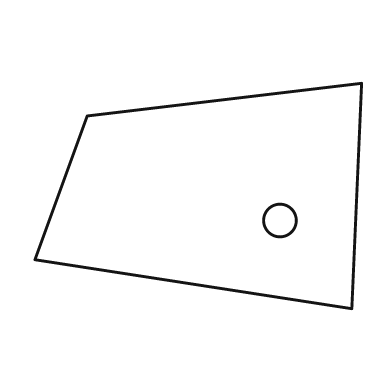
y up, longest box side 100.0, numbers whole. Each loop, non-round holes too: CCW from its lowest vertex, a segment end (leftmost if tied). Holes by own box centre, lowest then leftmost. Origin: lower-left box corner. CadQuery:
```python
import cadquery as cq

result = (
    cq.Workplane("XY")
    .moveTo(97.0, 0.0)
    .lineTo(100.0, 69.0)
    .lineTo(16.0, 59.0)
    .lineTo(0.0, 15.0)
    .close()
    .moveTo(75.0, 27.0)
    .circle(5.0)
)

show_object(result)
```